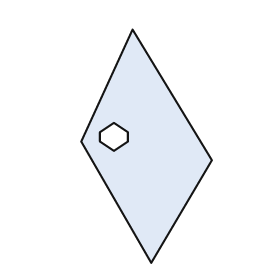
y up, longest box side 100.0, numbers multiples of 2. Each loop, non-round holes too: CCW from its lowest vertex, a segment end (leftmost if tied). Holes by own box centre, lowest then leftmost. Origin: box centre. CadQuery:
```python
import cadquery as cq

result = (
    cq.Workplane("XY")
    .moveTo(2.0, -50.0)
    .lineTo(28.0, -6.0)
    .lineTo(-6.0, 50.0)
    .lineTo(-28.0, 2.0)
    .close()
    .moveTo(-14.0, -2.0)
    .lineTo(-8.0, 2.0)
    .lineTo(-8.0, 6.0)
    .lineTo(-14.0, 10.0)
    .lineTo(-20.0, 6.0)
    .lineTo(-20.0, 2.0)
    .close()
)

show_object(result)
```